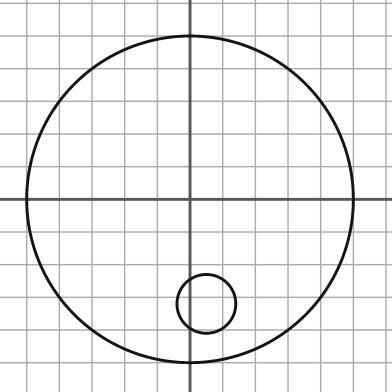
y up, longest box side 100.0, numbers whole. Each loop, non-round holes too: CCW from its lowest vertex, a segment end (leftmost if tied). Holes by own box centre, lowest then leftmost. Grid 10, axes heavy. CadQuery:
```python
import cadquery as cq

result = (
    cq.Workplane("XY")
    .moveTo(0.0, 0.0)
    .circle(50.0)
    .moveTo(5.0, -32.0)
    .circle(9.0)
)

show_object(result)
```